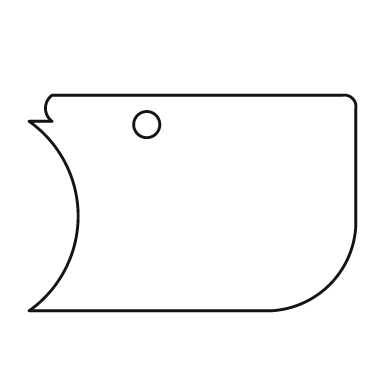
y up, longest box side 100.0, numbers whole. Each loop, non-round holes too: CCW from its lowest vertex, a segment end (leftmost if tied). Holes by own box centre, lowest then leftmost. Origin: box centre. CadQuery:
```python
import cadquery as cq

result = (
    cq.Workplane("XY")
    .moveTo(-50.0, -33.0)
    .lineTo(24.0, -33.0)
    .threePointArc((42.0, -25.0), (50.0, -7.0))
    .lineTo(50.0, 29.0)
    .threePointArc((49.0, 32.0), (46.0, 33.0))
    .lineTo(-43.0, 33.0)
    .threePointArc((-45.0, 29.0), (-43.0, 25.0))
    .lineTo(-50.0, 25.0)
    .threePointArc((-35.0, -4.0), (-50.0, -33.0))
    .close()
    .moveTo(-14.0, 24.0)
    .circle(4.0)
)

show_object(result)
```